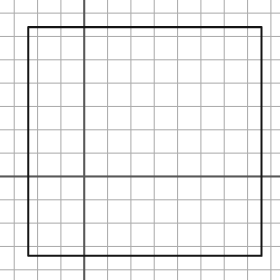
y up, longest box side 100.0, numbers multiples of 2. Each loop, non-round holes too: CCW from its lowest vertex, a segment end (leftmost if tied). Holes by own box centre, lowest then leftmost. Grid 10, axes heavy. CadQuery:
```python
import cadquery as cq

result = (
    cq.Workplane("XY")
    .moveTo(-24.0, -34.0)
    .lineTo(76.0, -34.0)
    .lineTo(76.0, 64.0)
    .lineTo(-24.0, 64.0)
    .close()
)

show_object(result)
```